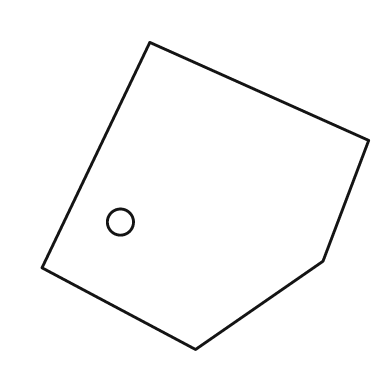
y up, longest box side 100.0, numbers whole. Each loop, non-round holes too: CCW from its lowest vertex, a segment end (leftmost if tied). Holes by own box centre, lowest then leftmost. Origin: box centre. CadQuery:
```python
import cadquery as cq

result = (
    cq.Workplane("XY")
    .moveTo(-3.0, -47.0)
    .lineTo(36.0, -20.0)
    .lineTo(50.0, 17.0)
    .lineTo(-17.0, 47.0)
    .lineTo(-50.0, -22.0)
    .close()
    .moveTo(-26.0, -8.0)
    .circle(4.0)
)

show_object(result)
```